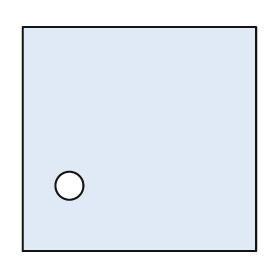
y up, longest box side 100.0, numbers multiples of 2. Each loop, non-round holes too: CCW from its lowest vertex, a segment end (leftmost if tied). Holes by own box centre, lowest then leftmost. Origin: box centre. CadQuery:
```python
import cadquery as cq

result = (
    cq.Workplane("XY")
    .moveTo(-50.0, -48.0)
    .lineTo(50.0, -48.0)
    .lineTo(50.0, 48.0)
    .lineTo(-50.0, 48.0)
    .close()
    .moveTo(-30.0, -20.0)
    .circle(6.0)
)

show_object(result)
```